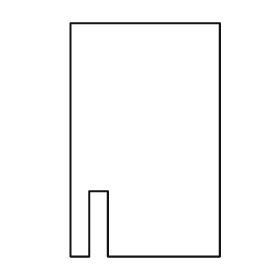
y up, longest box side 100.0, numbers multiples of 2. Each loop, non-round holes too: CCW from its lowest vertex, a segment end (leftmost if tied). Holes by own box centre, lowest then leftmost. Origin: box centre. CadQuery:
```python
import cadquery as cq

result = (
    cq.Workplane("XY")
    .moveTo(-32.0, -50.0)
    .lineTo(-24.0, -50.0)
    .lineTo(-24.0, -22.0)
    .lineTo(-16.0, -22.0)
    .lineTo(-16.0, -50.0)
    .lineTo(32.0, -50.0)
    .lineTo(32.0, 50.0)
    .lineTo(-32.0, 50.0)
    .close()
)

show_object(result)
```